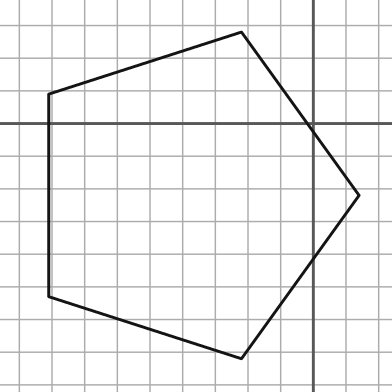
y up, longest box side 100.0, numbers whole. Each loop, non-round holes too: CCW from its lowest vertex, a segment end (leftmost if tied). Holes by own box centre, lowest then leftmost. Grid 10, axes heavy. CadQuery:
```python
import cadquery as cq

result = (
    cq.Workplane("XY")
    .moveTo(-22.0, -72.0)
    .lineTo(14.0, -22.0)
    .lineTo(-22.0, 28.0)
    .lineTo(-81.0, 9.0)
    .lineTo(-81.0, -53.0)
    .close()
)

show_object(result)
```